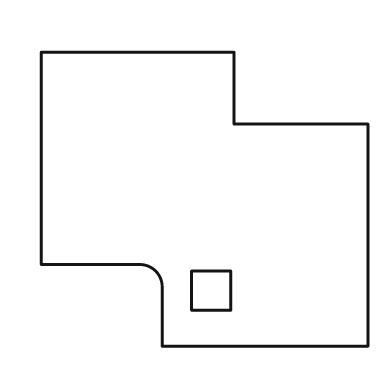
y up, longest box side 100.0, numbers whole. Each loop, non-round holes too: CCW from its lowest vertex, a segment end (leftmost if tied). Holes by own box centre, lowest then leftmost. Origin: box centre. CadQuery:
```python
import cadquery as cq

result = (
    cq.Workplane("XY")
    .moveTo(-13.0, -45.0)
    .lineTo(50.0, -45.0)
    .lineTo(50.0, 23.0)
    .lineTo(9.0, 23.0)
    .lineTo(9.0, 45.0)
    .lineTo(-50.0, 45.0)
    .lineTo(-50.0, -20.0)
    .lineTo(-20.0, -20.0)
    .threePointArc((-15.0, -22.0), (-13.0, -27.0))
    .close()
    .moveTo(-4.0, -34.0)
    .lineTo(8.0, -34.0)
    .lineTo(8.0, -22.0)
    .lineTo(-4.0, -22.0)
    .close()
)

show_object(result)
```